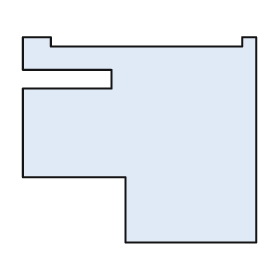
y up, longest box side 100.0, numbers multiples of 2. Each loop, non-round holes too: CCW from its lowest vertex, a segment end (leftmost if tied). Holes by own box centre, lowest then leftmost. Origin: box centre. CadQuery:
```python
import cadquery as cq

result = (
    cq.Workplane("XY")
    .moveTo(-6.0, -44.0)
    .lineTo(50.0, -44.0)
    .lineTo(50.0, 44.0)
    .lineTo(44.0, 44.0)
    .lineTo(44.0, 40.0)
    .lineTo(-38.0, 40.0)
    .lineTo(-38.0, 44.0)
    .lineTo(-50.0, 44.0)
    .lineTo(-50.0, 30.0)
    .lineTo(-12.0, 30.0)
    .lineTo(-12.0, 22.0)
    .lineTo(-50.0, 22.0)
    .lineTo(-50.0, -16.0)
    .lineTo(-6.0, -16.0)
    .close()
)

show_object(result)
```